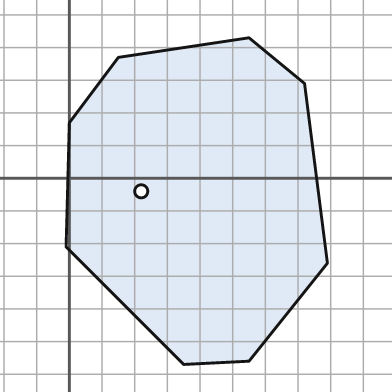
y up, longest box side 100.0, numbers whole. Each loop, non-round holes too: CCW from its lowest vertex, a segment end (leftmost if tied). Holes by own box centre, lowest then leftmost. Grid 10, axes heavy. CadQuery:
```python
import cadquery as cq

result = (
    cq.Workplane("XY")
    .moveTo(35.0, -57.0)
    .lineTo(55.0, -56.0)
    .lineTo(79.0, -26.0)
    .lineTo(72.0, 29.0)
    .lineTo(55.0, 43.0)
    .lineTo(15.0, 37.0)
    .lineTo(0.0, 17.0)
    .lineTo(-1.0, -21.0)
    .close()
    .moveTo(22.0, -4.0)
    .circle(2.0)
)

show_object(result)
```